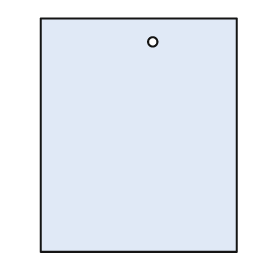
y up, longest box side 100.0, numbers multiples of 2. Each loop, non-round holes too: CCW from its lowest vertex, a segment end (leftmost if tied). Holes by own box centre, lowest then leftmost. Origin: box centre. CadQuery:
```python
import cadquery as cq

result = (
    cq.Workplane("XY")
    .moveTo(-42.0, -50.0)
    .lineTo(42.0, -50.0)
    .lineTo(42.0, 50.0)
    .lineTo(-42.0, 50.0)
    .close()
    .moveTo(6.0, 40.0)
    .circle(2.0)
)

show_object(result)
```